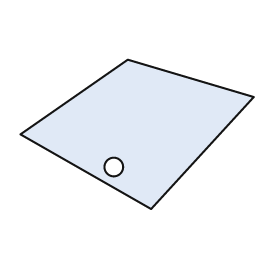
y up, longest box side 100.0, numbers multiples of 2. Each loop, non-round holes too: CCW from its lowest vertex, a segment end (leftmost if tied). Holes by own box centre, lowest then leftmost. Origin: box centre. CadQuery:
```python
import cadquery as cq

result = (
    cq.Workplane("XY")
    .moveTo(6.0, -32.0)
    .lineTo(50.0, 16.0)
    .lineTo(-4.0, 32.0)
    .lineTo(-50.0, 0.0)
    .close()
    .moveTo(-10.0, -14.0)
    .circle(4.0)
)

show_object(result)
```